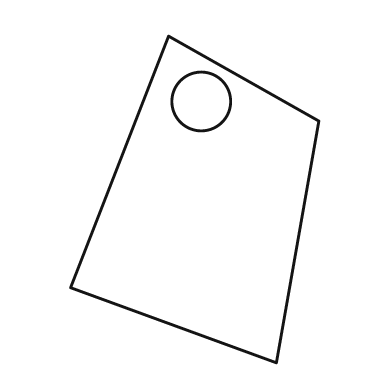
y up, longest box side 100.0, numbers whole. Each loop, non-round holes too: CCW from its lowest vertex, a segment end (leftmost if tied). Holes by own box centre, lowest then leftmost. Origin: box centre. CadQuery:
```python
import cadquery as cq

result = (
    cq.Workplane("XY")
    .moveTo(25.0, -50.0)
    .lineTo(38.0, 24.0)
    .lineTo(-8.0, 50.0)
    .lineTo(-38.0, -27.0)
    .close()
    .moveTo(2.0, 30.0)
    .circle(9.0)
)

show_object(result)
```